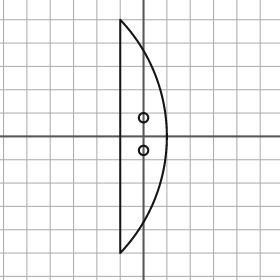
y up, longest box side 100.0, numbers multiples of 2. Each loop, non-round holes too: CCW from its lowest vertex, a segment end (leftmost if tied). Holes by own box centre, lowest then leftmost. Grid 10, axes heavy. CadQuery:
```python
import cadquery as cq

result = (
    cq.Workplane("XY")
    .moveTo(-10.0, -50.0)
    .threePointArc((10.0, 0.0), (-10.0, 50.0))
    .close()
    .moveTo(0.0, -6.0)
    .circle(2.0)
    .moveTo(0.0, 8.0)
    .circle(2.0)
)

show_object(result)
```